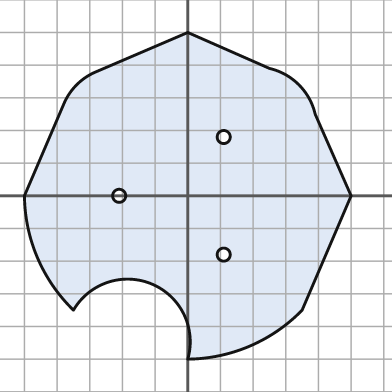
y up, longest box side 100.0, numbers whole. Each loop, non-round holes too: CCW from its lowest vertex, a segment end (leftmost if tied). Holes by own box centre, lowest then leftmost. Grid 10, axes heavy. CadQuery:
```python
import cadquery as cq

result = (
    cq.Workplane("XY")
    .moveTo(0.0, -50.0)
    .threePointArc((19.0, -46.0), (35.0, -35.0))
    .lineTo(50.0, 0.0)
    .lineTo(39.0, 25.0)
    .threePointArc((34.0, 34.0), (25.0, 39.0))
    .lineTo(0.0, 50.0)
    .lineTo(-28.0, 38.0)
    .threePointArc((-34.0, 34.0), (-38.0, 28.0))
    .lineTo(-50.0, 0.0)
    .threePointArc((-46.0, -19.0), (-35.0, -35.0))
    .threePointArc((-11.0, -27.0), (0.0, -50.0))
    .close()
    .moveTo(11.0, -18.0)
    .circle(2.0)
    .moveTo(-21.0, 0.0)
    .circle(2.0)
    .moveTo(11.0, 18.0)
    .circle(2.0)
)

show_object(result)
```